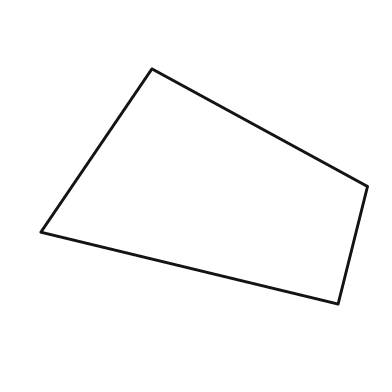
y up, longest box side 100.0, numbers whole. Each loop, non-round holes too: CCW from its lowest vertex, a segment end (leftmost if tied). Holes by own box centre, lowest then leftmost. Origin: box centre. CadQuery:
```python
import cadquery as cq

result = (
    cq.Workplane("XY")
    .moveTo(41.0, -36.0)
    .lineTo(50.0, 0.0)
    .lineTo(-16.0, 36.0)
    .lineTo(-50.0, -14.0)
    .close()
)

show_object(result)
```